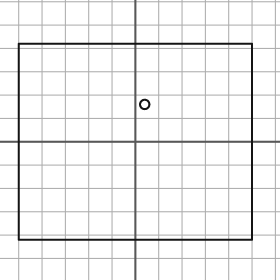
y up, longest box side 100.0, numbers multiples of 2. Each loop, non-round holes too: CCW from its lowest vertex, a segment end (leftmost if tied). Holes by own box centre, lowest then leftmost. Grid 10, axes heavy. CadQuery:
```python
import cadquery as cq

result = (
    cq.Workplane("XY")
    .moveTo(-50.0, -42.0)
    .lineTo(50.0, -42.0)
    .lineTo(50.0, 42.0)
    .lineTo(-50.0, 42.0)
    .close()
    .moveTo(4.0, 16.0)
    .circle(2.0)
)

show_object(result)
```